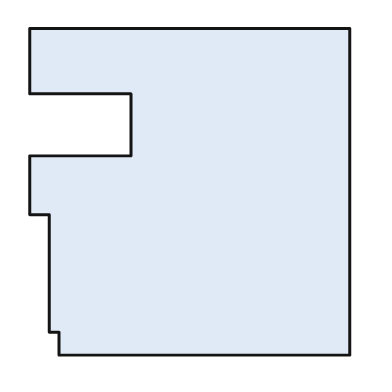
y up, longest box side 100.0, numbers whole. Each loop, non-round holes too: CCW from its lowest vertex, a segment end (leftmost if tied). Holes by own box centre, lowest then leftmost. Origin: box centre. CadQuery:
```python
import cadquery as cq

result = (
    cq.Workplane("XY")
    .moveTo(-40.0, -50.0)
    .lineTo(49.0, -50.0)
    .lineTo(49.0, 50.0)
    .lineTo(-49.0, 50.0)
    .lineTo(-49.0, 30.0)
    .lineTo(-18.0, 30.0)
    .lineTo(-18.0, 11.0)
    .lineTo(-49.0, 11.0)
    .lineTo(-49.0, -7.0)
    .lineTo(-43.0, -7.0)
    .lineTo(-43.0, -43.0)
    .lineTo(-40.0, -43.0)
    .close()
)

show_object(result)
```